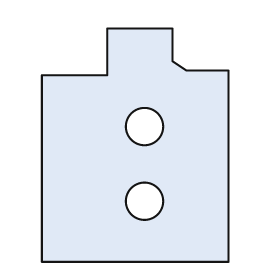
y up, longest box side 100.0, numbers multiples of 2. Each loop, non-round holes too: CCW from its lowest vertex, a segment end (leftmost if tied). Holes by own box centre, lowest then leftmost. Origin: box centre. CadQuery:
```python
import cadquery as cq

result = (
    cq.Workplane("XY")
    .moveTo(-40.0, -50.0)
    .lineTo(40.0, -50.0)
    .lineTo(40.0, 32.0)
    .lineTo(22.0, 32.0)
    .lineTo(16.0, 36.0)
    .lineTo(16.0, 50.0)
    .lineTo(-12.0, 50.0)
    .lineTo(-12.0, 30.0)
    .lineTo(-40.0, 30.0)
    .close()
    .moveTo(4.0, -24.0)
    .circle(8.0)
    .moveTo(4.0, 8.0)
    .circle(8.0)
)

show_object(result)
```